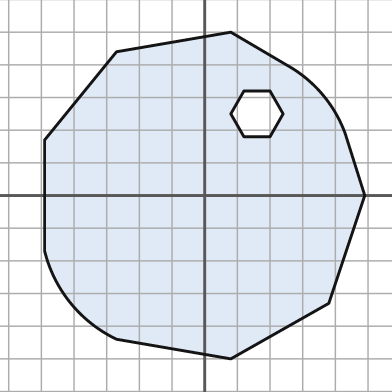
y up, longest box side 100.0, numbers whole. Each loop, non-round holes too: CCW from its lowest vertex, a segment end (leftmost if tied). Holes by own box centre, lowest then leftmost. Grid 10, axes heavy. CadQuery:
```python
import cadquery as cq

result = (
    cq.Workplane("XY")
    .moveTo(8.0, -50.0)
    .lineTo(38.0, -33.0)
    .lineTo(49.0, 0.0)
    .lineTo(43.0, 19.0)
    .threePointArc((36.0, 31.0), (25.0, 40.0))
    .lineTo(8.0, 50.0)
    .lineTo(-27.0, 44.0)
    .lineTo(-49.0, 17.0)
    .lineTo(-49.0, -17.0)
    .threePointArc((-41.0, -33.0), (-27.0, -44.0))
    .close()
    .moveTo(12.0, 18.0)
    .lineTo(20.0, 18.0)
    .lineTo(24.0, 25.0)
    .lineTo(20.0, 32.0)
    .lineTo(12.0, 32.0)
    .lineTo(8.0, 25.0)
    .close()
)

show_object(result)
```